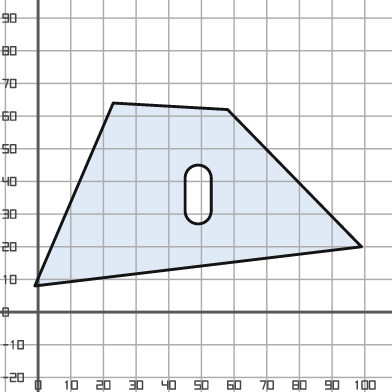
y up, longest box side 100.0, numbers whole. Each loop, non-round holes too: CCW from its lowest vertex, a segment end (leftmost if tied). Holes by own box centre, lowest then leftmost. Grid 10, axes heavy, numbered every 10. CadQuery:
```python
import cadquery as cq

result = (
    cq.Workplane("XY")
    .moveTo(-1.0, 8.0)
    .lineTo(99.0, 20.0)
    .lineTo(58.0, 62.0)
    .lineTo(23.0, 64.0)
    .close()
    .moveTo(45.0, 31.0)
    .threePointArc((49.0, 27.0), (53.0, 31.0))
    .lineTo(53.0, 41.0)
    .threePointArc((49.0, 45.0), (45.0, 41.0))
    .close()
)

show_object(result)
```